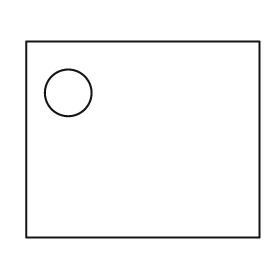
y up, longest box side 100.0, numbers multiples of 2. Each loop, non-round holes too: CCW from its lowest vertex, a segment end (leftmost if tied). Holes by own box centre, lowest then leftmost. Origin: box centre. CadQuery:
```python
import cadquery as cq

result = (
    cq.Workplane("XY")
    .moveTo(-50.0, -42.0)
    .lineTo(50.0, -42.0)
    .lineTo(50.0, 42.0)
    .lineTo(-50.0, 42.0)
    .close()
    .moveTo(-32.0, 20.0)
    .circle(10.0)
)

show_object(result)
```